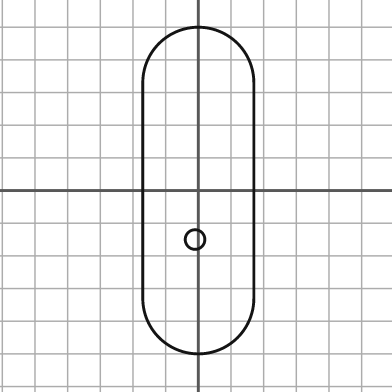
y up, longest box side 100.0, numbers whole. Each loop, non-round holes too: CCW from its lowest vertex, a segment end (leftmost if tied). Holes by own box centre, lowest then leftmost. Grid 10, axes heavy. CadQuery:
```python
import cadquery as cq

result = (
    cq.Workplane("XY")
    .moveTo(-17.0, -33.0)
    .threePointArc((0.0, -50.0), (17.0, -33.0))
    .lineTo(17.0, 33.0)
    .threePointArc((0.0, 50.0), (-17.0, 33.0))
    .close()
    .moveTo(-1.0, -15.0)
    .circle(3.0)
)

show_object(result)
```